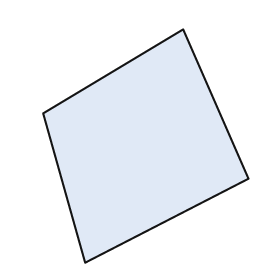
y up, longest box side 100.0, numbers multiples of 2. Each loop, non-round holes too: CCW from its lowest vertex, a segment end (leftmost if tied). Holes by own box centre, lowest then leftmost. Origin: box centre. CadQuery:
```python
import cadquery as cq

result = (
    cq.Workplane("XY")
    .moveTo(-26.0, -50.0)
    .lineTo(44.0, -14.0)
    .lineTo(16.0, 50.0)
    .lineTo(-44.0, 14.0)
    .close()
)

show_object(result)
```